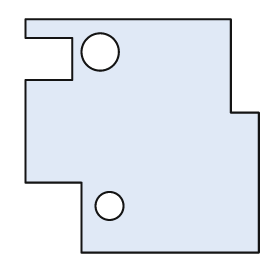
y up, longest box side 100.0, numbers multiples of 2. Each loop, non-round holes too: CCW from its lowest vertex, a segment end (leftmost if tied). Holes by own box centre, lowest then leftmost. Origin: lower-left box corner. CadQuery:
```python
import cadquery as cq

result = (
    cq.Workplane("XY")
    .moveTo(24.0, 0.0)
    .lineTo(100.0, 0.0)
    .lineTo(100.0, 60.0)
    .lineTo(88.0, 60.0)
    .lineTo(88.0, 100.0)
    .lineTo(0.0, 100.0)
    .lineTo(0.0, 92.0)
    .lineTo(20.0, 92.0)
    .lineTo(20.0, 74.0)
    .lineTo(0.0, 74.0)
    .lineTo(0.0, 30.0)
    .lineTo(24.0, 30.0)
    .close()
    .moveTo(36.0, 20.0)
    .circle(6.0)
    .moveTo(32.0, 86.0)
    .circle(8.0)
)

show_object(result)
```